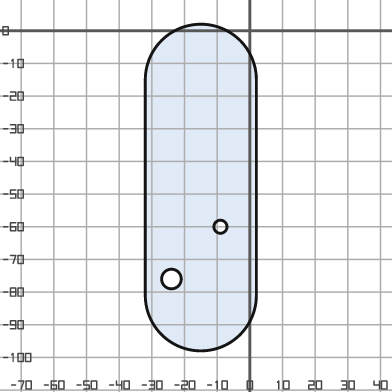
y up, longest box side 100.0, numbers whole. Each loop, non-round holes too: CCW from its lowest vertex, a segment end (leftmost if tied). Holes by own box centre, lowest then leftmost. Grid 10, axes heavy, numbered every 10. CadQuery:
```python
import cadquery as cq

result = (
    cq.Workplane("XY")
    .moveTo(-32.0, -81.0)
    .threePointArc((-15.0, -98.0), (2.0, -81.0))
    .lineTo(2.0, -15.0)
    .threePointArc((-15.0, 2.0), (-32.0, -15.0))
    .close()
    .moveTo(-24.0, -76.0)
    .circle(3.0)
    .moveTo(-9.0, -60.0)
    .circle(2.0)
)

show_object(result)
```